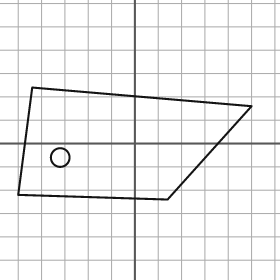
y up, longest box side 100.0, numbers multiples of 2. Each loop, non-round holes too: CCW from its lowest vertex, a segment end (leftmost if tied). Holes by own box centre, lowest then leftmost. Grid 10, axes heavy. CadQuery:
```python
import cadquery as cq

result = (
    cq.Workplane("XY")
    .moveTo(14.0, -24.0)
    .lineTo(50.0, 16.0)
    .lineTo(-44.0, 24.0)
    .lineTo(-50.0, -22.0)
    .close()
    .moveTo(-32.0, -6.0)
    .circle(4.0)
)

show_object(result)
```